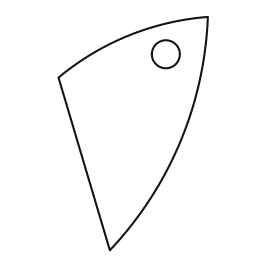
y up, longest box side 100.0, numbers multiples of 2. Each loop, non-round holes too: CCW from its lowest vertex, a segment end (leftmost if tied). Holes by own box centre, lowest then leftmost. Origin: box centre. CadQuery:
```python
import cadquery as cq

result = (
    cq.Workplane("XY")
    .moveTo(-10.0, -50.0)
    .threePointArc((20.0, -4.0), (32.0, 50.0))
    .threePointArc((-2.0, 42.0), (-32.0, 24.0))
    .close()
    .moveTo(14.0, 34.0)
    .circle(6.0)
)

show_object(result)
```